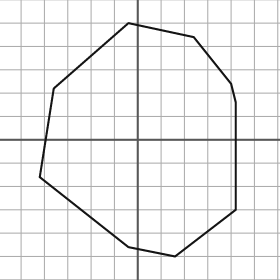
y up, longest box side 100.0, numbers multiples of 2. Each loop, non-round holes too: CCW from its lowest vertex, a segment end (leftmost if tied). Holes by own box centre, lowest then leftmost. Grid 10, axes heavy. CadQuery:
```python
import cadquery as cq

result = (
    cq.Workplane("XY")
    .moveTo(16.0, -50.0)
    .lineTo(42.0, -30.0)
    .lineTo(42.0, 16.0)
    .lineTo(40.0, 24.0)
    .lineTo(24.0, 44.0)
    .lineTo(-4.0, 50.0)
    .lineTo(-36.0, 22.0)
    .lineTo(-42.0, -16.0)
    .lineTo(-4.0, -46.0)
    .close()
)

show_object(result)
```